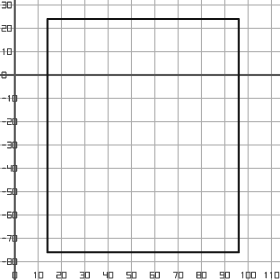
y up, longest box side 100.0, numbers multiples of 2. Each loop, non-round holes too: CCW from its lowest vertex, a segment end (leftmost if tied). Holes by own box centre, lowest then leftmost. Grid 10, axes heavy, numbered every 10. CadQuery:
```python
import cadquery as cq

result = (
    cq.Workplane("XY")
    .moveTo(14.0, -76.0)
    .lineTo(96.0, -76.0)
    .lineTo(96.0, 24.0)
    .lineTo(14.0, 24.0)
    .close()
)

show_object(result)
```